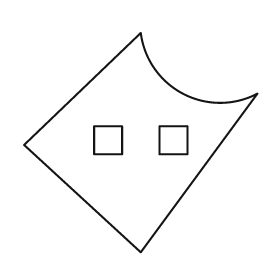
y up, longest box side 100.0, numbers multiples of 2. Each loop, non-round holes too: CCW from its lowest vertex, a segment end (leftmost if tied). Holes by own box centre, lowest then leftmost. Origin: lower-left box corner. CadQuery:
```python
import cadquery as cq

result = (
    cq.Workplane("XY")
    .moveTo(50.0, 0.0)
    .lineTo(100.0, 68.0)
    .threePointArc((68.0, 68.0), (50.0, 94.0))
    .lineTo(0.0, 46.0)
    .close()
    .moveTo(30.0, 42.0)
    .lineTo(42.0, 42.0)
    .lineTo(42.0, 54.0)
    .lineTo(30.0, 54.0)
    .close()
    .moveTo(58.0, 42.0)
    .lineTo(70.0, 42.0)
    .lineTo(70.0, 54.0)
    .lineTo(58.0, 54.0)
    .close()
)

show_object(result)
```